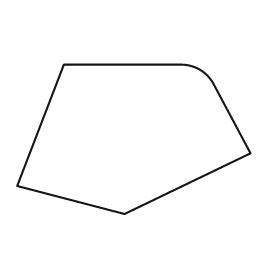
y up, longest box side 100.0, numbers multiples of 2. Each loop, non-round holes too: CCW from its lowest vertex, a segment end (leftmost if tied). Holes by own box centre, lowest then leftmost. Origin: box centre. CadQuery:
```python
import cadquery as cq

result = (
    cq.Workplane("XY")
    .moveTo(-4.0, -32.0)
    .lineTo(50.0, -6.0)
    .lineTo(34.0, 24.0)
    .threePointArc((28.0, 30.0), (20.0, 32.0))
    .lineTo(-30.0, 32.0)
    .lineTo(-50.0, -20.0)
    .close()
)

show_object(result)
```